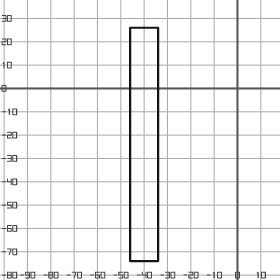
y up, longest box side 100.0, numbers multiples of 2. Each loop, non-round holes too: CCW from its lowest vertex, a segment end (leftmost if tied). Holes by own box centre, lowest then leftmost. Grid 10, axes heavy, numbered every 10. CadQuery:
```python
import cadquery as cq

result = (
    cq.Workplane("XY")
    .moveTo(-46.0, -74.0)
    .lineTo(-34.0, -74.0)
    .lineTo(-34.0, 26.0)
    .lineTo(-46.0, 26.0)
    .close()
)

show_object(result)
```